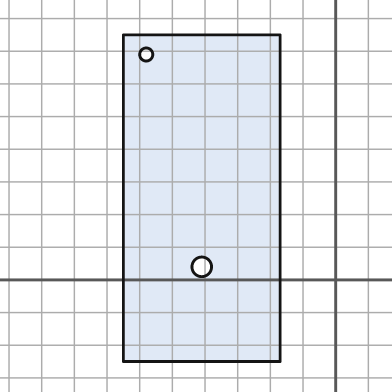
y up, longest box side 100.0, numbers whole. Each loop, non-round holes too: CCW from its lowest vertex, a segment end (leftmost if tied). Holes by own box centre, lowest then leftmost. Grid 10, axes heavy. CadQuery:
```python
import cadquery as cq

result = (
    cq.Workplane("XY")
    .moveTo(-65.0, -25.0)
    .lineTo(-17.0, -25.0)
    .lineTo(-17.0, 75.0)
    .lineTo(-65.0, 75.0)
    .close()
    .moveTo(-41.0, 4.0)
    .circle(3.0)
    .moveTo(-58.0, 69.0)
    .circle(2.0)
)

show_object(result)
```